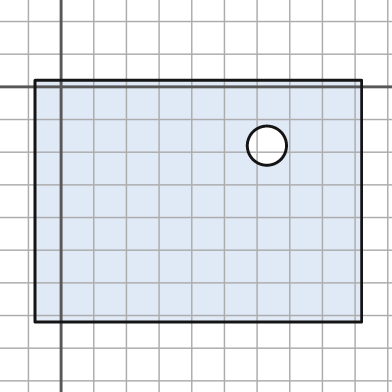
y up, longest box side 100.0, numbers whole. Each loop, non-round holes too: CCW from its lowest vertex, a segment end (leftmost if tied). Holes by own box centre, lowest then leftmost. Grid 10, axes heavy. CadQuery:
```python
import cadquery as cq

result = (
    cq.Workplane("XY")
    .moveTo(-8.0, -72.0)
    .lineTo(92.0, -72.0)
    .lineTo(92.0, 2.0)
    .lineTo(-8.0, 2.0)
    .close()
    .moveTo(63.0, -18.0)
    .circle(6.0)
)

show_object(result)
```